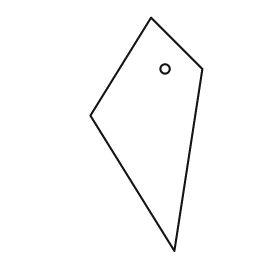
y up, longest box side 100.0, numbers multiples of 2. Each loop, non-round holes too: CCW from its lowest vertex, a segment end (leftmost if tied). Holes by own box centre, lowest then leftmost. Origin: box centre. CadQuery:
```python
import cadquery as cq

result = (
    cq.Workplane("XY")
    .moveTo(12.0, -50.0)
    .lineTo(24.0, 28.0)
    .lineTo(2.0, 50.0)
    .lineTo(-24.0, 8.0)
    .close()
    .moveTo(8.0, 28.0)
    .circle(2.0)
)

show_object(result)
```